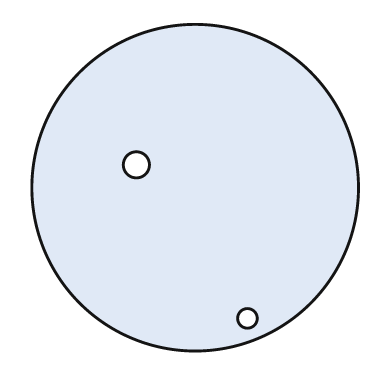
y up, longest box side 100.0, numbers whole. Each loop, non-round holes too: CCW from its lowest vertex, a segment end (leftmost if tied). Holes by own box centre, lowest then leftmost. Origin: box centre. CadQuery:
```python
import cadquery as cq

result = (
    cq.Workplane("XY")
    .moveTo(0.0, 0.0)
    .circle(50.0)
    .moveTo(16.0, -40.0)
    .circle(3.0)
    .moveTo(-18.0, 7.0)
    .circle(4.0)
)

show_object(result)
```